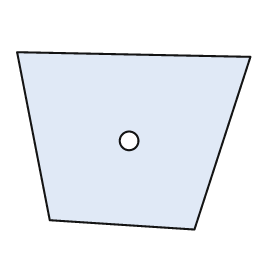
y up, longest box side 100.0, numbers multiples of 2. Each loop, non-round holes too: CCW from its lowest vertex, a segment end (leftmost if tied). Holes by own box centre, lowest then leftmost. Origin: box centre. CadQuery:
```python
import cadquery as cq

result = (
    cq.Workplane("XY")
    .moveTo(26.0, -38.0)
    .lineTo(50.0, 36.0)
    .lineTo(-50.0, 38.0)
    .lineTo(-36.0, -34.0)
    .close()
    .moveTo(-2.0, 0.0)
    .circle(4.0)
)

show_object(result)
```